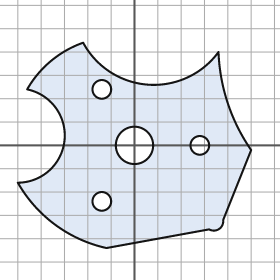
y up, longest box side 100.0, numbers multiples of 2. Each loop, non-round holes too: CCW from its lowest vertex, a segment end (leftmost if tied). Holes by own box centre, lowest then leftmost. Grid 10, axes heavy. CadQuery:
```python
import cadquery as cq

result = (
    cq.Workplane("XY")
    .moveTo(-12.0, -44.0)
    .lineTo(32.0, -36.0)
    .threePointArc((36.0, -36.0), (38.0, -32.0))
    .lineTo(50.0, -2.0)
    .threePointArc((40.0, 18.0), (36.0, 40.0))
    .threePointArc((6.0, 26.0), (-22.0, 44.0))
    .threePointArc((-36.0, 36.0), (-46.0, 24.0))
    .threePointArc((-30.0, 2.0), (-50.0, -16.0))
    .threePointArc((-34.0, -34.0), (-12.0, -44.0))
    .close()
    .moveTo(-14.0, -24.0)
    .circle(4.0)
    .moveTo(0.0, 0.0)
    .circle(8.0)
    .moveTo(28.0, 0.0)
    .circle(4.0)
    .moveTo(-14.0, 24.0)
    .circle(4.0)
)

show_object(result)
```